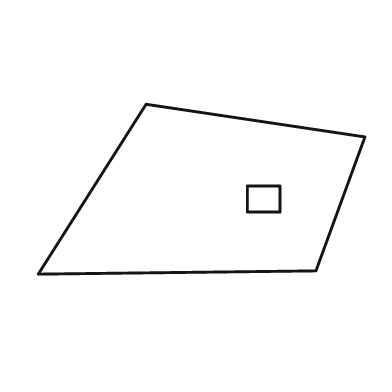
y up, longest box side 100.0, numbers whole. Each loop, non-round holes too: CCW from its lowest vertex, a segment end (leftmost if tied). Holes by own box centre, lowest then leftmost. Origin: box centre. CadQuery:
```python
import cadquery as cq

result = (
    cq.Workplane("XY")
    .moveTo(-50.0, -26.0)
    .lineTo(35.0, -25.0)
    .lineTo(50.0, 16.0)
    .lineTo(-17.0, 26.0)
    .close()
    .moveTo(14.0, -7.0)
    .lineTo(24.0, -7.0)
    .lineTo(24.0, 1.0)
    .lineTo(14.0, 1.0)
    .close()
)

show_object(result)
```